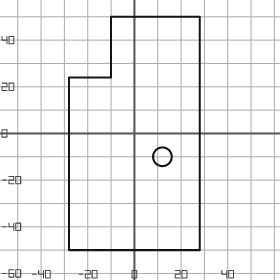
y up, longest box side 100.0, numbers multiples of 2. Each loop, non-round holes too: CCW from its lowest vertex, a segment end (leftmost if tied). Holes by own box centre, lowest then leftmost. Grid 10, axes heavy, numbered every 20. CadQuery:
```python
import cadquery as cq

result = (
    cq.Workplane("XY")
    .moveTo(-28.0, -50.0)
    .lineTo(28.0, -50.0)
    .lineTo(28.0, 50.0)
    .lineTo(-10.0, 50.0)
    .lineTo(-10.0, 24.0)
    .lineTo(-28.0, 24.0)
    .close()
    .moveTo(12.0, -10.0)
    .circle(4.0)
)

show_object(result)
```